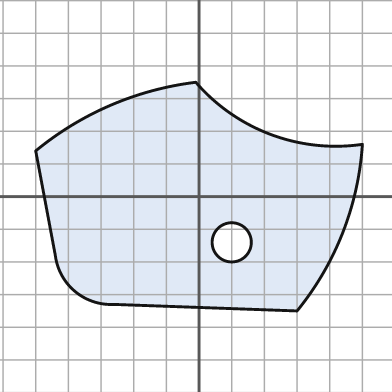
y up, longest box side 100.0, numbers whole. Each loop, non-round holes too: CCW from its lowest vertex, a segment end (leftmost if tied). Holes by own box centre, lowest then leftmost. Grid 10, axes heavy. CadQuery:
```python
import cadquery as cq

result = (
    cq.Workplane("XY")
    .moveTo(30.0, -35.0)
    .threePointArc((44.0, -11.0), (50.0, 16.0))
    .threePointArc((22.0, 19.0), (-1.0, 35.0))
    .threePointArc((-27.0, 28.0), (-50.0, 14.0))
    .lineTo(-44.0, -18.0)
    .threePointArc((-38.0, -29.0), (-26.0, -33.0))
    .close()
    .moveTo(10.0, -14.0)
    .circle(6.0)
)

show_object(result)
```